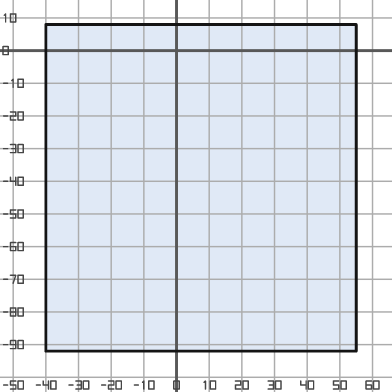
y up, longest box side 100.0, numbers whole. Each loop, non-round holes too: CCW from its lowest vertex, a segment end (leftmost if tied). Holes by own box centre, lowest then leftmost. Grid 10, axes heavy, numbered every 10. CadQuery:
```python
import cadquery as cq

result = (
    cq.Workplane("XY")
    .moveTo(-40.0, -92.0)
    .lineTo(55.0, -92.0)
    .lineTo(55.0, 8.0)
    .lineTo(-40.0, 8.0)
    .close()
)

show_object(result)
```